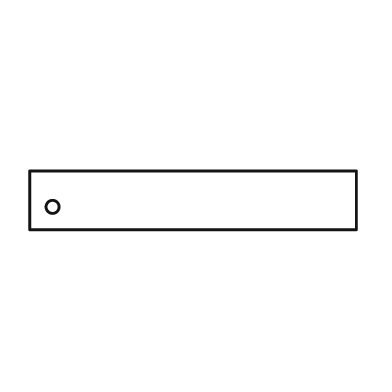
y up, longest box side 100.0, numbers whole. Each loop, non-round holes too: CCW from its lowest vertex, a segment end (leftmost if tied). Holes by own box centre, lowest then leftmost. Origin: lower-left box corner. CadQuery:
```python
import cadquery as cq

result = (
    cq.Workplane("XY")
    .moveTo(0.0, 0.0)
    .lineTo(100.0, 0.0)
    .lineTo(100.0, 18.0)
    .lineTo(0.0, 18.0)
    .close()
    .moveTo(7.0, 7.0)
    .circle(2.0)
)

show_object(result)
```